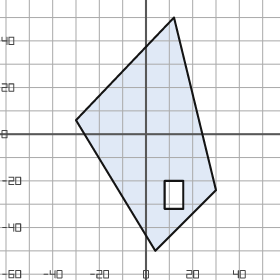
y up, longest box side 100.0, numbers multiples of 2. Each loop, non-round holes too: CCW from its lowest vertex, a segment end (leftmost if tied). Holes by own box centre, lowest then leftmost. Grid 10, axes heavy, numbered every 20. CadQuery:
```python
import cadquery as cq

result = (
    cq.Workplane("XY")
    .moveTo(4.0, -50.0)
    .lineTo(30.0, -24.0)
    .lineTo(12.0, 50.0)
    .lineTo(-30.0, 6.0)
    .close()
    .moveTo(8.0, -32.0)
    .lineTo(16.0, -32.0)
    .lineTo(16.0, -20.0)
    .lineTo(8.0, -20.0)
    .close()
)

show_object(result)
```